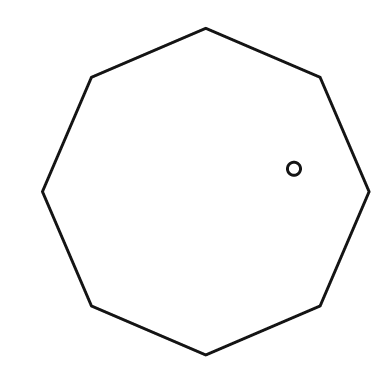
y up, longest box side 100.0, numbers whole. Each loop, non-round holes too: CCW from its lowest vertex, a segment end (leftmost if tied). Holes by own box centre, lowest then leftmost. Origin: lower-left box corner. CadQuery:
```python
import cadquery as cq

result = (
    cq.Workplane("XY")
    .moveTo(50.0, 0.0)
    .lineTo(85.0, 15.0)
    .lineTo(100.0, 50.0)
    .lineTo(85.0, 85.0)
    .lineTo(50.0, 100.0)
    .lineTo(15.0, 85.0)
    .lineTo(0.0, 50.0)
    .lineTo(15.0, 15.0)
    .close()
    .moveTo(77.0, 57.0)
    .circle(2.0)
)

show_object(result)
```